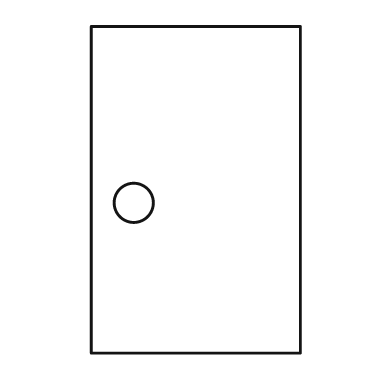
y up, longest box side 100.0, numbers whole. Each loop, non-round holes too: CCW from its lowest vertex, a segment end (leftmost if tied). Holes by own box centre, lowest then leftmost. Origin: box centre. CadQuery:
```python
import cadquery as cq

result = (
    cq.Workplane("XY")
    .moveTo(-32.0, -50.0)
    .lineTo(32.0, -50.0)
    .lineTo(32.0, 50.0)
    .lineTo(-32.0, 50.0)
    .close()
    .moveTo(-19.0, -4.0)
    .circle(6.0)
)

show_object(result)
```